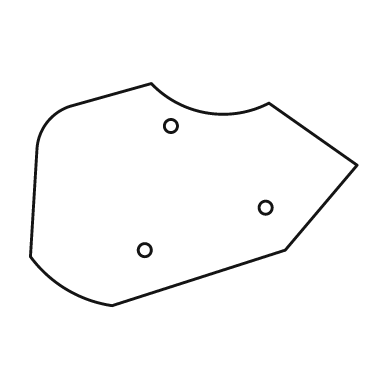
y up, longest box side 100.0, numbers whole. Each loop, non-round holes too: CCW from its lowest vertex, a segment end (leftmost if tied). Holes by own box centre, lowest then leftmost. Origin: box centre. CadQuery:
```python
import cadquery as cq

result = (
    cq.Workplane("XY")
    .moveTo(-25.0, -34.0)
    .lineTo(28.0, -17.0)
    .lineTo(50.0, 9.0)
    .lineTo(23.0, 28.0)
    .threePointArc((4.0, 25.0), (-13.0, 34.0))
    .lineTo(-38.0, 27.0)
    .threePointArc((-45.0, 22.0), (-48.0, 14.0))
    .lineTo(-50.0, -19.0)
    .threePointArc((-39.0, -29.0), (-25.0, -34.0))
    .close()
    .moveTo(-15.0, -17.0)
    .circle(2.0)
    .moveTo(22.0, -4.0)
    .circle(2.0)
    .moveTo(-7.0, 21.0)
    .circle(2.0)
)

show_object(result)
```